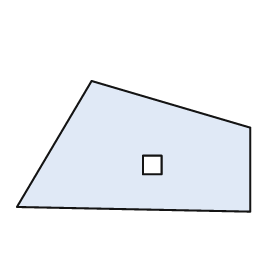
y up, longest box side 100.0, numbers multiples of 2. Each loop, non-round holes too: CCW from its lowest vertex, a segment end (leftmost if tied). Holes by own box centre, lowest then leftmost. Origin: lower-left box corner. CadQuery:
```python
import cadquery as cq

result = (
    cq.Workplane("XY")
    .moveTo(100.0, 0.0)
    .lineTo(100.0, 36.0)
    .lineTo(32.0, 56.0)
    .lineTo(0.0, 2.0)
    .close()
    .moveTo(54.0, 16.0)
    .lineTo(62.0, 16.0)
    .lineTo(62.0, 24.0)
    .lineTo(54.0, 24.0)
    .close()
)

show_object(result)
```